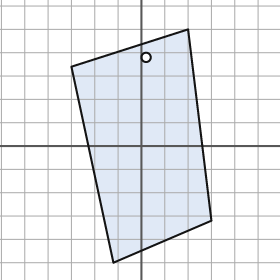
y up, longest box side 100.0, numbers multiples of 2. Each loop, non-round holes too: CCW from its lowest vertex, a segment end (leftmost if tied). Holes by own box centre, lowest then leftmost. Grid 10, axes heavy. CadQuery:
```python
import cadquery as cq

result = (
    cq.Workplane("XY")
    .moveTo(-12.0, -50.0)
    .lineTo(30.0, -32.0)
    .lineTo(20.0, 50.0)
    .lineTo(-30.0, 34.0)
    .close()
    .moveTo(2.0, 38.0)
    .circle(2.0)
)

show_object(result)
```